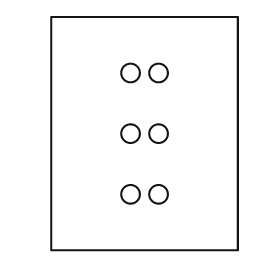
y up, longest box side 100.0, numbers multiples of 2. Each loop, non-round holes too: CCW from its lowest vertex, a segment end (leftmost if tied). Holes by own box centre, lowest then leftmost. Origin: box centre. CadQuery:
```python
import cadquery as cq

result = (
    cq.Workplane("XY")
    .moveTo(-40.0, -50.0)
    .lineTo(40.0, -50.0)
    .lineTo(40.0, 50.0)
    .lineTo(-40.0, 50.0)
    .close()
    .moveTo(-6.0, -26.0)
    .circle(4.0)
    .moveTo(6.0, -26.0)
    .circle(4.0)
    .moveTo(-6.0, 0.0)
    .circle(4.0)
    .moveTo(6.0, 0.0)
    .circle(4.0)
    .moveTo(-6.0, 26.0)
    .circle(4.0)
    .moveTo(6.0, 26.0)
    .circle(4.0)
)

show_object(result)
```